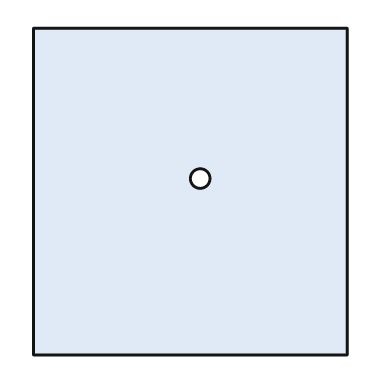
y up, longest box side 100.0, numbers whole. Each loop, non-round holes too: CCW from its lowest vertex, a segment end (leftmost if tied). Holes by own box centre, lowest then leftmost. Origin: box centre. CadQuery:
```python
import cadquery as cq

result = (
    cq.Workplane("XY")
    .moveTo(-48.0, -50.0)
    .lineTo(48.0, -50.0)
    .lineTo(48.0, 50.0)
    .lineTo(-48.0, 50.0)
    .close()
    .moveTo(3.0, 4.0)
    .circle(3.0)
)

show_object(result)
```